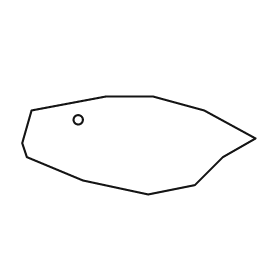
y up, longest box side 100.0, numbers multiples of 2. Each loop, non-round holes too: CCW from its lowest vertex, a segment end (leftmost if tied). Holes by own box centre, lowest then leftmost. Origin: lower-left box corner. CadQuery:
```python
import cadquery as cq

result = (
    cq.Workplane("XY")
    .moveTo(54.0, 0.0)
    .lineTo(74.0, 4.0)
    .lineTo(86.0, 16.0)
    .lineTo(100.0, 24.0)
    .lineTo(78.0, 36.0)
    .lineTo(56.0, 42.0)
    .lineTo(36.0, 42.0)
    .lineTo(4.0, 36.0)
    .lineTo(0.0, 22.0)
    .lineTo(2.0, 16.0)
    .lineTo(26.0, 6.0)
    .close()
    .moveTo(24.0, 32.0)
    .circle(2.0)
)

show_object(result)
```